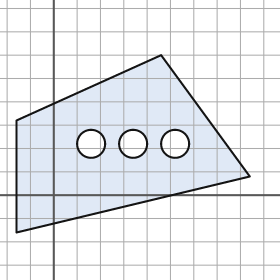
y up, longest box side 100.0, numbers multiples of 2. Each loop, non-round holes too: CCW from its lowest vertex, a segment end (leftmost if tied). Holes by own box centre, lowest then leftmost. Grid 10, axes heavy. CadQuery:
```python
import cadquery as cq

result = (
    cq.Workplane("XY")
    .moveTo(-16.0, -16.0)
    .lineTo(84.0, 8.0)
    .lineTo(46.0, 60.0)
    .lineTo(-16.0, 32.0)
    .close()
    .moveTo(16.0, 22.0)
    .circle(6.0)
    .moveTo(34.0, 22.0)
    .circle(6.0)
    .moveTo(52.0, 22.0)
    .circle(6.0)
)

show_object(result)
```